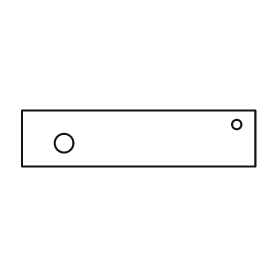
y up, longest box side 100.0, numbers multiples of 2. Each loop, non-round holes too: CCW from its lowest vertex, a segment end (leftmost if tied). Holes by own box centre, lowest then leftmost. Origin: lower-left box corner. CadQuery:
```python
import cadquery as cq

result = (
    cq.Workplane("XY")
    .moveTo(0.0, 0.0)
    .lineTo(100.0, 0.0)
    .lineTo(100.0, 24.0)
    .lineTo(0.0, 24.0)
    .close()
    .moveTo(18.0, 10.0)
    .circle(4.0)
    .moveTo(92.0, 18.0)
    .circle(2.0)
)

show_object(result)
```